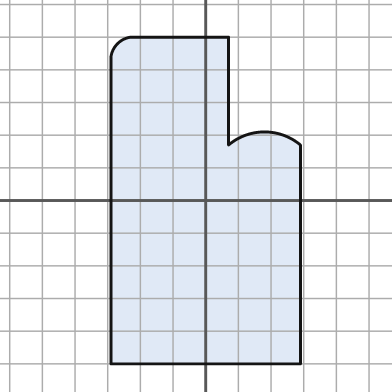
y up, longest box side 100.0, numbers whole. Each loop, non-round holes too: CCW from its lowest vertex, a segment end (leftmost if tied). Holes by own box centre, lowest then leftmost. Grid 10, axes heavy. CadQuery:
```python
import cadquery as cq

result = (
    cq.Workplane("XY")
    .moveTo(-29.0, -50.0)
    .lineTo(29.0, -50.0)
    .lineTo(29.0, 17.0)
    .threePointArc((18.0, 21.0), (7.0, 17.0))
    .lineTo(7.0, 50.0)
    .lineTo(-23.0, 50.0)
    .threePointArc((-27.0, 48.0), (-29.0, 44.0))
    .close()
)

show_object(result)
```